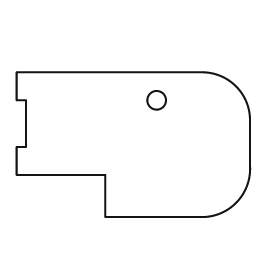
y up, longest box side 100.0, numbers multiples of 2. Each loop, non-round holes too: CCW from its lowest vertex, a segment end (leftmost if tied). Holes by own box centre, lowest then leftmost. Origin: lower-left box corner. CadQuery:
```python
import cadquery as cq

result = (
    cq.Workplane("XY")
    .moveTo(38.0, 0.0)
    .lineTo(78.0, 0.0)
    .threePointArc((94.0, 6.0), (100.0, 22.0))
    .lineTo(100.0, 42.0)
    .threePointArc((94.0, 56.0), (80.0, 62.0))
    .lineTo(0.0, 62.0)
    .lineTo(0.0, 50.0)
    .lineTo(4.0, 50.0)
    .lineTo(4.0, 30.0)
    .lineTo(0.0, 30.0)
    .lineTo(0.0, 18.0)
    .lineTo(38.0, 18.0)
    .close()
    .moveTo(60.0, 50.0)
    .circle(4.0)
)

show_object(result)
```